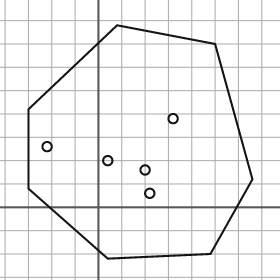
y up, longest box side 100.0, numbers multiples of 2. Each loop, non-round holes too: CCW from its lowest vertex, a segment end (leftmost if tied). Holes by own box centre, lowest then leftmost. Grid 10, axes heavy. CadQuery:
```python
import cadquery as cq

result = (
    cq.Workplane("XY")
    .moveTo(4.0, -22.0)
    .lineTo(48.0, -20.0)
    .lineTo(66.0, 12.0)
    .lineTo(50.0, 70.0)
    .lineTo(8.0, 78.0)
    .lineTo(-30.0, 42.0)
    .lineTo(-30.0, 8.0)
    .close()
    .moveTo(22.0, 6.0)
    .circle(2.0)
    .moveTo(20.0, 16.0)
    .circle(2.0)
    .moveTo(4.0, 20.0)
    .circle(2.0)
    .moveTo(-22.0, 26.0)
    .circle(2.0)
    .moveTo(32.0, 38.0)
    .circle(2.0)
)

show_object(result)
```